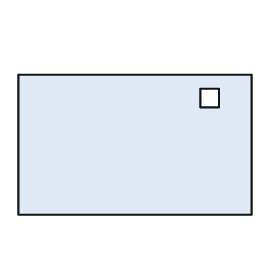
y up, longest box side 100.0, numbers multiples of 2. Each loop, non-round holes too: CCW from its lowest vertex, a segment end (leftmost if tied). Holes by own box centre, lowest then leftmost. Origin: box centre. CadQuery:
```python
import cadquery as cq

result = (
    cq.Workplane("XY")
    .moveTo(-50.0, -30.0)
    .lineTo(50.0, -30.0)
    .lineTo(50.0, 30.0)
    .lineTo(-50.0, 30.0)
    .close()
    .moveTo(28.0, 16.0)
    .lineTo(36.0, 16.0)
    .lineTo(36.0, 24.0)
    .lineTo(28.0, 24.0)
    .close()
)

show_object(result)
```